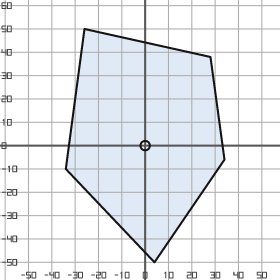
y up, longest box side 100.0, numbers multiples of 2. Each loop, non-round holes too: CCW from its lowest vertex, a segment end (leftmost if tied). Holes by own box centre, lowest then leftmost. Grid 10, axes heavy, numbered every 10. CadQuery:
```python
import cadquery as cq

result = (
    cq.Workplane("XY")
    .moveTo(4.0, -50.0)
    .lineTo(34.0, -6.0)
    .lineTo(28.0, 38.0)
    .lineTo(-26.0, 50.0)
    .lineTo(-34.0, -10.0)
    .close()
    .moveTo(0.0, 0.0)
    .circle(2.0)
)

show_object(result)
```